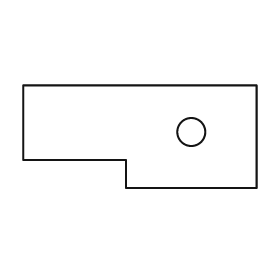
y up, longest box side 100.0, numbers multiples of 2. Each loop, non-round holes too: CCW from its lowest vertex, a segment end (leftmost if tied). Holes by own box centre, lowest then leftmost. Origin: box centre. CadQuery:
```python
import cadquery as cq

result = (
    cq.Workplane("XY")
    .moveTo(-6.0, -22.0)
    .lineTo(50.0, -22.0)
    .lineTo(50.0, 22.0)
    .lineTo(-50.0, 22.0)
    .lineTo(-50.0, -10.0)
    .lineTo(-6.0, -10.0)
    .close()
    .moveTo(22.0, 2.0)
    .circle(6.0)
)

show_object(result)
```